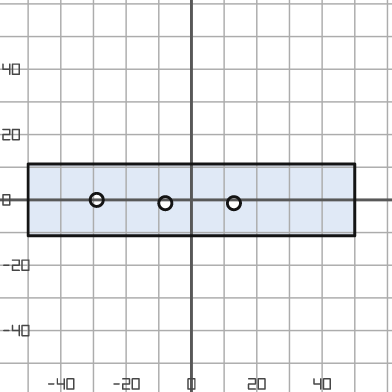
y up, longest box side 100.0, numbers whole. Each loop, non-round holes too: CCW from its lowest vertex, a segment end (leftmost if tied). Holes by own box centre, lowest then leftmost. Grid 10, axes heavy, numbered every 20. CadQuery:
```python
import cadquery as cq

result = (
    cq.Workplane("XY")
    .moveTo(-50.0, -11.0)
    .lineTo(50.0, -11.0)
    .lineTo(50.0, 11.0)
    .lineTo(-50.0, 11.0)
    .close()
    .moveTo(-8.0, -1.0)
    .circle(2.0)
    .moveTo(13.0, -1.0)
    .circle(2.0)
    .moveTo(-29.0, 0.0)
    .circle(2.0)
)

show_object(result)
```